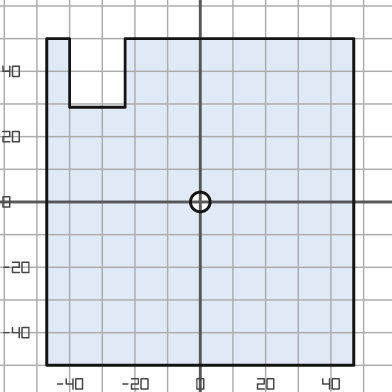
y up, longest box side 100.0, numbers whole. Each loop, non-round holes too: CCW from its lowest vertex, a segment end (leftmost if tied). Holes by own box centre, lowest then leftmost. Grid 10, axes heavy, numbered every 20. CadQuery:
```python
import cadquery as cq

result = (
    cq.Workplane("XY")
    .moveTo(-47.0, -50.0)
    .lineTo(47.0, -50.0)
    .lineTo(47.0, 50.0)
    .lineTo(-23.0, 50.0)
    .lineTo(-23.0, 29.0)
    .lineTo(-40.0, 29.0)
    .lineTo(-40.0, 50.0)
    .lineTo(-47.0, 50.0)
    .close()
    .moveTo(0.0, 0.0)
    .circle(3.0)
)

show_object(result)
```